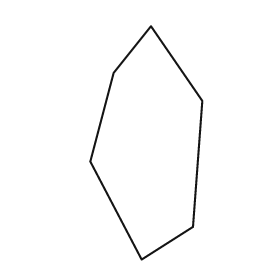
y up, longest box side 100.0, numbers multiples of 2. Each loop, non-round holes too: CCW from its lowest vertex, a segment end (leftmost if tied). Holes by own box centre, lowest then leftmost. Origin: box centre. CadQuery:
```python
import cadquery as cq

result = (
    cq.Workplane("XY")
    .moveTo(-2.0, -50.0)
    .lineTo(20.0, -36.0)
    .lineTo(24.0, 18.0)
    .lineTo(2.0, 50.0)
    .lineTo(-14.0, 30.0)
    .lineTo(-24.0, -8.0)
    .close()
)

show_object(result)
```